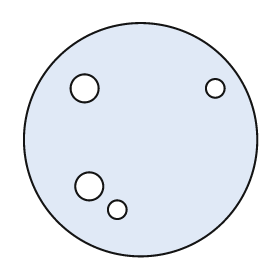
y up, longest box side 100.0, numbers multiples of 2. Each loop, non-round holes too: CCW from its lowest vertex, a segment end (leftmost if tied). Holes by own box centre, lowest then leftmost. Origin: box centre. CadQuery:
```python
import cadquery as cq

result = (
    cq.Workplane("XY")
    .moveTo(0.0, 0.0)
    .circle(50.0)
    .moveTo(-10.0, -30.0)
    .circle(4.0)
    .moveTo(-22.0, -20.0)
    .circle(6.0)
    .moveTo(-24.0, 22.0)
    .circle(6.0)
    .moveTo(32.0, 22.0)
    .circle(4.0)
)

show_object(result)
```